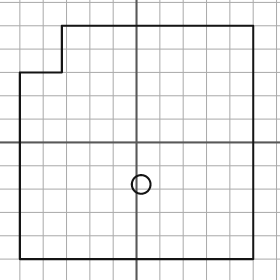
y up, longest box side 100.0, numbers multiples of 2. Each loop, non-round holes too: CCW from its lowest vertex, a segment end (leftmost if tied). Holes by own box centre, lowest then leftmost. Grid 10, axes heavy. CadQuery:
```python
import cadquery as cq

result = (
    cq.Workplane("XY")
    .moveTo(-50.0, -50.0)
    .lineTo(50.0, -50.0)
    .lineTo(50.0, 50.0)
    .lineTo(-32.0, 50.0)
    .lineTo(-32.0, 30.0)
    .lineTo(-50.0, 30.0)
    .close()
    .moveTo(2.0, -18.0)
    .circle(4.0)
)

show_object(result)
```